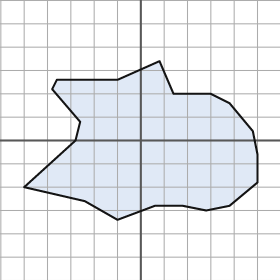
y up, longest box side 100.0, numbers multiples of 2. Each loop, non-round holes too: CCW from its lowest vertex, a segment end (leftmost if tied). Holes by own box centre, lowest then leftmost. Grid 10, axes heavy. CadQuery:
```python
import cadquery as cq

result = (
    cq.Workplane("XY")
    .moveTo(-10.0, -34.0)
    .lineTo(6.0, -28.0)
    .lineTo(18.0, -28.0)
    .lineTo(28.0, -30.0)
    .lineTo(38.0, -28.0)
    .lineTo(50.0, -18.0)
    .lineTo(50.0, -6.0)
    .lineTo(48.0, 4.0)
    .lineTo(38.0, 16.0)
    .lineTo(30.0, 20.0)
    .lineTo(14.0, 20.0)
    .lineTo(8.0, 34.0)
    .lineTo(-10.0, 26.0)
    .lineTo(-36.0, 26.0)
    .lineTo(-38.0, 22.0)
    .lineTo(-26.0, 8.0)
    .lineTo(-28.0, 0.0)
    .lineTo(-50.0, -20.0)
    .lineTo(-24.0, -26.0)
    .close()
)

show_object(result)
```